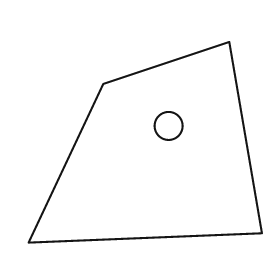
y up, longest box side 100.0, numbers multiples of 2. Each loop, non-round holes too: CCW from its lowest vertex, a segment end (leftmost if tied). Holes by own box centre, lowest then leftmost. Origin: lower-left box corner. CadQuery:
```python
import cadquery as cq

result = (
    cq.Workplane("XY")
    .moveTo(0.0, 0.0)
    .lineTo(100.0, 4.0)
    .lineTo(86.0, 86.0)
    .lineTo(32.0, 68.0)
    .close()
    .moveTo(60.0, 50.0)
    .circle(6.0)
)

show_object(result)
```